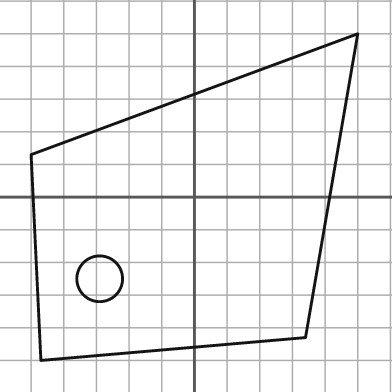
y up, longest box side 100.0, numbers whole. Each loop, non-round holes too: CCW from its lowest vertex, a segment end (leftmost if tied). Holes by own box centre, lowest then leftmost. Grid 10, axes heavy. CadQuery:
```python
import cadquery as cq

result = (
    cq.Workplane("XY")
    .moveTo(-47.0, -50.0)
    .lineTo(34.0, -43.0)
    .lineTo(50.0, 50.0)
    .lineTo(-50.0, 13.0)
    .close()
    .moveTo(-29.0, -25.0)
    .circle(7.0)
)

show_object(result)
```